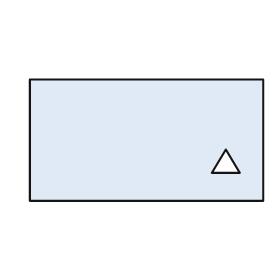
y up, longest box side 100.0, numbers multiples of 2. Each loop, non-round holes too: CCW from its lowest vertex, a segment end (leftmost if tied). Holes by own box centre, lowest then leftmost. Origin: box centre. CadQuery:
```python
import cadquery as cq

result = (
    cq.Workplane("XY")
    .moveTo(-50.0, -26.0)
    .lineTo(50.0, -26.0)
    .lineTo(50.0, 26.0)
    .lineTo(-50.0, 26.0)
    .close()
    .moveTo(28.0, -14.0)
    .lineTo(40.0, -14.0)
    .lineTo(34.0, -4.0)
    .close()
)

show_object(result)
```